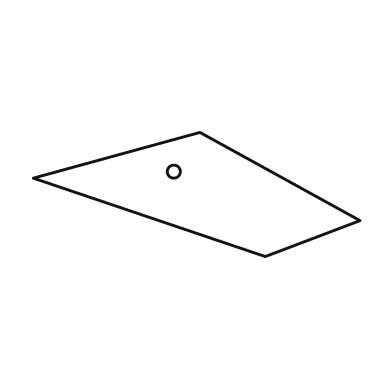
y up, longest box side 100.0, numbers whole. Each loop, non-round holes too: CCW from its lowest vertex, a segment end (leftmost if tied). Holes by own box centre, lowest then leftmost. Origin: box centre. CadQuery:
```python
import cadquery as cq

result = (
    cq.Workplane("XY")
    .moveTo(21.0, -19.0)
    .lineTo(50.0, -8.0)
    .lineTo(1.0, 19.0)
    .lineTo(-50.0, 5.0)
    .close()
    .moveTo(-7.0, 7.0)
    .circle(2.0)
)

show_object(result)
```